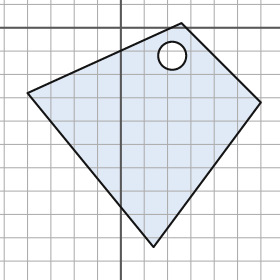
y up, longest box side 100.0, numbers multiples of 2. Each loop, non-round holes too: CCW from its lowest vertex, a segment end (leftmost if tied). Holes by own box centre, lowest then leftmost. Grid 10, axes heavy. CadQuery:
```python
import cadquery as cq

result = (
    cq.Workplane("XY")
    .moveTo(14.0, -94.0)
    .lineTo(60.0, -32.0)
    .lineTo(26.0, 2.0)
    .lineTo(-40.0, -28.0)
    .close()
    .moveTo(22.0, -12.0)
    .circle(6.0)
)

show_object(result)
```